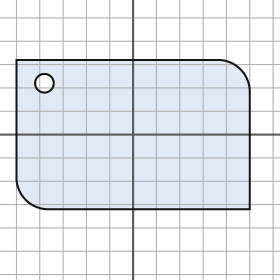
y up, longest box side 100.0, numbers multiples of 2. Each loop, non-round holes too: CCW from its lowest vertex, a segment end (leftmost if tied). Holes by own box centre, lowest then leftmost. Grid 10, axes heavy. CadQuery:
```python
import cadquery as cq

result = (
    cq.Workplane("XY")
    .moveTo(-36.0, -32.0)
    .lineTo(50.0, -32.0)
    .lineTo(50.0, 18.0)
    .threePointArc((46.0, 28.0), (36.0, 32.0))
    .lineTo(-50.0, 32.0)
    .lineTo(-50.0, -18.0)
    .threePointArc((-46.0, -28.0), (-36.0, -32.0))
    .close()
    .moveTo(-38.0, 22.0)
    .circle(4.0)
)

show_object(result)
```